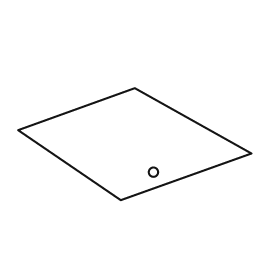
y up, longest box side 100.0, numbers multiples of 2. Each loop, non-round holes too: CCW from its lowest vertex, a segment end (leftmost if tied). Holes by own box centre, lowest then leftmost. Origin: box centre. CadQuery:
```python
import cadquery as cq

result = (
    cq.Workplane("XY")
    .moveTo(-6.0, -24.0)
    .lineTo(50.0, -4.0)
    .lineTo(0.0, 24.0)
    .lineTo(-50.0, 6.0)
    .close()
    .moveTo(8.0, -12.0)
    .circle(2.0)
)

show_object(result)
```